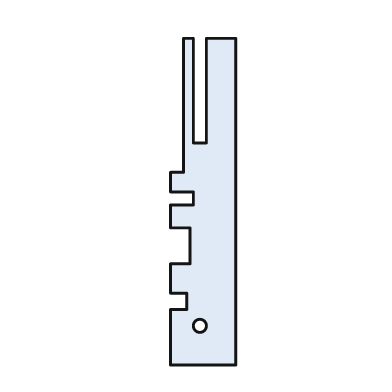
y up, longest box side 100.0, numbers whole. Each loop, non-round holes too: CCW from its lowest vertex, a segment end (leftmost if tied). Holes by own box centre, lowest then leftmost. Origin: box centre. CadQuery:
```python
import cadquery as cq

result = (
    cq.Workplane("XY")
    .moveTo(-10.0, -50.0)
    .lineTo(10.0, -50.0)
    .lineTo(10.0, 50.0)
    .lineTo(1.0, 50.0)
    .lineTo(1.0, 18.0)
    .lineTo(-3.0, 18.0)
    .lineTo(-3.0, 50.0)
    .lineTo(-6.0, 50.0)
    .lineTo(-6.0, 9.0)
    .lineTo(-10.0, 9.0)
    .lineTo(-10.0, 3.0)
    .lineTo(-3.0, 3.0)
    .lineTo(-3.0, -1.0)
    .lineTo(-10.0, -1.0)
    .lineTo(-10.0, -8.0)
    .lineTo(-4.0, -8.0)
    .lineTo(-4.0, -19.0)
    .lineTo(-10.0, -19.0)
    .lineTo(-10.0, -28.0)
    .lineTo(-5.0, -28.0)
    .lineTo(-5.0, -33.0)
    .lineTo(-10.0, -33.0)
    .close()
    .moveTo(-1.0, -38.0)
    .circle(2.0)
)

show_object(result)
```